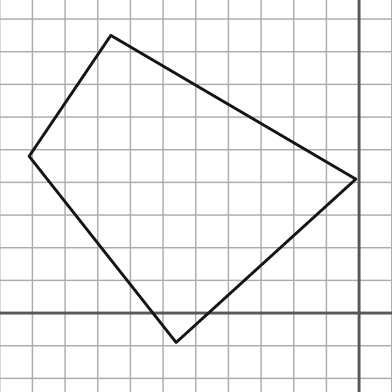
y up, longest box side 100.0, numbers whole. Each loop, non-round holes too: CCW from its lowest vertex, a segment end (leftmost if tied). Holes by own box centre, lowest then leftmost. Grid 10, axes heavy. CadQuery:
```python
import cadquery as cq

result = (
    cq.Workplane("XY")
    .moveTo(-56.0, -9.0)
    .lineTo(-1.0, 41.0)
    .lineTo(-76.0, 85.0)
    .lineTo(-101.0, 48.0)
    .close()
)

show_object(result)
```